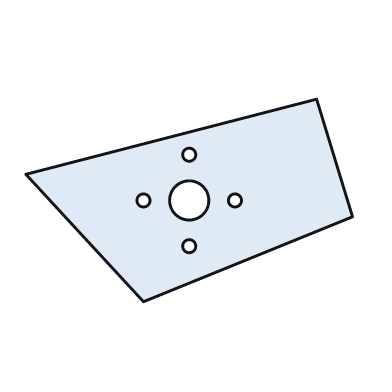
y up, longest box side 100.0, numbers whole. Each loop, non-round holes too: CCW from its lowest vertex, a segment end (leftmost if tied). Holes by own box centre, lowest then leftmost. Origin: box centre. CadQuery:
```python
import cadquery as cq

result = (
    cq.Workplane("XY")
    .moveTo(-14.0, -31.0)
    .lineTo(50.0, -5.0)
    .lineTo(39.0, 31.0)
    .lineTo(-50.0, 8.0)
    .close()
    .moveTo(0.0, -14.0)
    .circle(2.0)
    .moveTo(-14.0, 0.0)
    .circle(2.0)
    .moveTo(0.0, 0.0)
    .circle(6.0)
    .moveTo(14.0, 0.0)
    .circle(2.0)
    .moveTo(0.0, 14.0)
    .circle(2.0)
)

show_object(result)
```